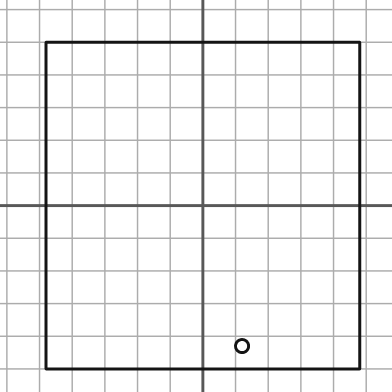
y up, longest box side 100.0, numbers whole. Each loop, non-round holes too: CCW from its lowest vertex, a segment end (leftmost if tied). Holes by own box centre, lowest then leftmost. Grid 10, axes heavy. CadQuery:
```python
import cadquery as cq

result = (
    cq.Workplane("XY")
    .moveTo(-48.0, -50.0)
    .lineTo(48.0, -50.0)
    .lineTo(48.0, 50.0)
    .lineTo(-48.0, 50.0)
    .close()
    .moveTo(12.0, -43.0)
    .circle(2.0)
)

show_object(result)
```